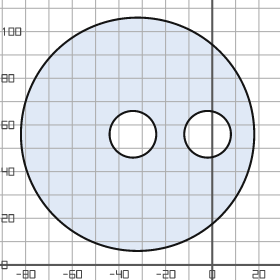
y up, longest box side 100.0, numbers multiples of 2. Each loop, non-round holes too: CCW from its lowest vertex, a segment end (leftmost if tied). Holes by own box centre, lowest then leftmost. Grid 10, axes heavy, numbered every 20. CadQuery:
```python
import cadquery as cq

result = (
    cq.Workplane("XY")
    .moveTo(-32.0, 56.0)
    .circle(50.0)
    .moveTo(-34.0, 56.0)
    .circle(10.0)
    .moveTo(-2.0, 56.0)
    .circle(10.0)
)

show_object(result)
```